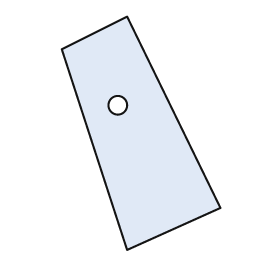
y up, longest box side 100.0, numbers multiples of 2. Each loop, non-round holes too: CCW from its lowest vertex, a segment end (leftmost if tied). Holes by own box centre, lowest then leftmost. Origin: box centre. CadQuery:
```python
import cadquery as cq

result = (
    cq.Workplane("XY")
    .moveTo(-6.0, -50.0)
    .lineTo(34.0, -32.0)
    .lineTo(-6.0, 50.0)
    .lineTo(-34.0, 36.0)
    .close()
    .moveTo(-10.0, 12.0)
    .circle(4.0)
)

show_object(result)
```